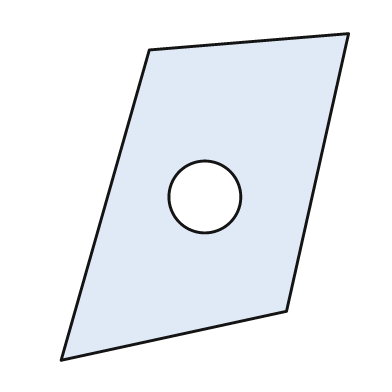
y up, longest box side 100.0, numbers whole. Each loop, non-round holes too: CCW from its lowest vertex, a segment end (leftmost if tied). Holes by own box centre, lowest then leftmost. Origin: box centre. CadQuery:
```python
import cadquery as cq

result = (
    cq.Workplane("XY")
    .moveTo(-44.0, -50.0)
    .lineTo(25.0, -35.0)
    .lineTo(44.0, 50.0)
    .lineTo(-17.0, 45.0)
    .close()
    .moveTo(0.0, 0.0)
    .circle(11.0)
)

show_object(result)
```